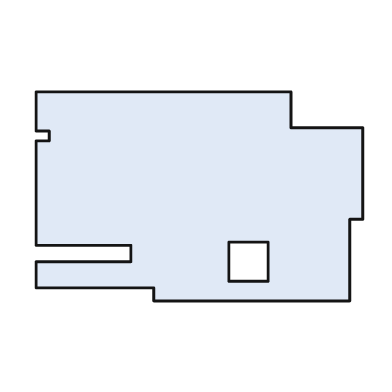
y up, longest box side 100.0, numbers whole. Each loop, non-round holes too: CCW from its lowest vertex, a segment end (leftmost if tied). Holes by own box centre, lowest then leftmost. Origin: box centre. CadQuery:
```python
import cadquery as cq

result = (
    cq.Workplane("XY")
    .moveTo(-14.0, -32.0)
    .lineTo(46.0, -32.0)
    .lineTo(46.0, -7.0)
    .lineTo(50.0, -7.0)
    .lineTo(50.0, 21.0)
    .lineTo(28.0, 21.0)
    .lineTo(28.0, 32.0)
    .lineTo(-50.0, 32.0)
    .lineTo(-50.0, 20.0)
    .lineTo(-46.0, 20.0)
    .lineTo(-46.0, 17.0)
    .lineTo(-50.0, 17.0)
    .lineTo(-50.0, -15.0)
    .lineTo(-21.0, -15.0)
    .lineTo(-21.0, -20.0)
    .lineTo(-50.0, -20.0)
    .lineTo(-50.0, -28.0)
    .lineTo(-14.0, -28.0)
    .close()
    .moveTo(9.0, -26.0)
    .lineTo(21.0, -26.0)
    .lineTo(21.0, -14.0)
    .lineTo(9.0, -14.0)
    .close()
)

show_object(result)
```